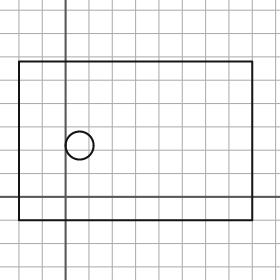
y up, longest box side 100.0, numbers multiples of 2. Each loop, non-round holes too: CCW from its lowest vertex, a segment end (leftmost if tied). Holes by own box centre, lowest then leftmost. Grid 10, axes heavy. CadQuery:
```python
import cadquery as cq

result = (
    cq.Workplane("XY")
    .moveTo(-20.0, -10.0)
    .lineTo(80.0, -10.0)
    .lineTo(80.0, 58.0)
    .lineTo(-20.0, 58.0)
    .close()
    .moveTo(6.0, 22.0)
    .circle(6.0)
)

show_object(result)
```